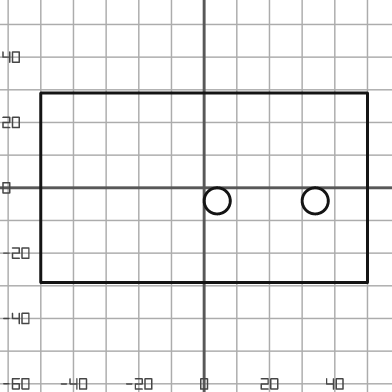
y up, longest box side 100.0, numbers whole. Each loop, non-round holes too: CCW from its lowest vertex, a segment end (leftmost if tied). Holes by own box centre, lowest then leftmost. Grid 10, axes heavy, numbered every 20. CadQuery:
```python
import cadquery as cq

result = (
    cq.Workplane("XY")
    .moveTo(-50.0, -29.0)
    .lineTo(50.0, -29.0)
    .lineTo(50.0, 29.0)
    .lineTo(-50.0, 29.0)
    .close()
    .moveTo(4.0, -4.0)
    .circle(4.0)
    .moveTo(34.0, -4.0)
    .circle(4.0)
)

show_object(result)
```